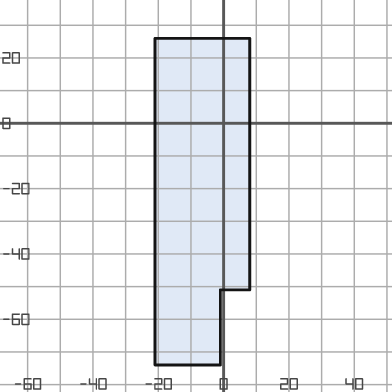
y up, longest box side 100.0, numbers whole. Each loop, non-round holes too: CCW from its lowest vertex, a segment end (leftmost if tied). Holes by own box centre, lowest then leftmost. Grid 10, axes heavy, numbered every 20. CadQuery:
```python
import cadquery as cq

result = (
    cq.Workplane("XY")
    .moveTo(-21.0, -74.0)
    .lineTo(-1.0, -74.0)
    .lineTo(-1.0, -51.0)
    .lineTo(8.0, -51.0)
    .lineTo(8.0, 26.0)
    .lineTo(-21.0, 26.0)
    .close()
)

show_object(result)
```